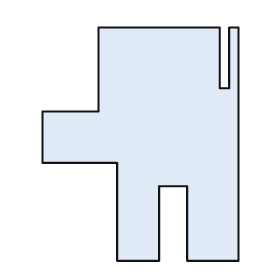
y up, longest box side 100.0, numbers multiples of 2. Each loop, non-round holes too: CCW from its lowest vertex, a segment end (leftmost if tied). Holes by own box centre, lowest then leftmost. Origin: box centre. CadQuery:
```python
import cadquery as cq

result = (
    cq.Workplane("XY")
    .moveTo(-10.0, -50.0)
    .lineTo(8.0, -50.0)
    .lineTo(8.0, -18.0)
    .lineTo(20.0, -18.0)
    .lineTo(20.0, -50.0)
    .lineTo(42.0, -50.0)
    .lineTo(42.0, 50.0)
    .lineTo(38.0, 50.0)
    .lineTo(38.0, 24.0)
    .lineTo(34.0, 24.0)
    .lineTo(34.0, 50.0)
    .lineTo(-18.0, 50.0)
    .lineTo(-18.0, 14.0)
    .lineTo(-42.0, 14.0)
    .lineTo(-42.0, -8.0)
    .lineTo(-10.0, -8.0)
    .close()
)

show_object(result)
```